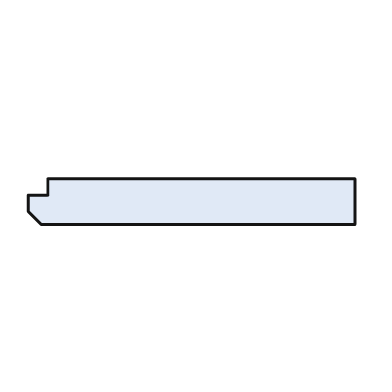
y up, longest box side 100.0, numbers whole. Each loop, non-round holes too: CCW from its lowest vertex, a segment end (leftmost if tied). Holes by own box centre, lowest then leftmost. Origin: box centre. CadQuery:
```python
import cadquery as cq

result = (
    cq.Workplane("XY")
    .moveTo(-46.0, -7.0)
    .lineTo(50.0, -7.0)
    .lineTo(50.0, 7.0)
    .lineTo(-44.0, 7.0)
    .lineTo(-44.0, 2.0)
    .lineTo(-50.0, 2.0)
    .lineTo(-50.0, -3.0)
    .close()
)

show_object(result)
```